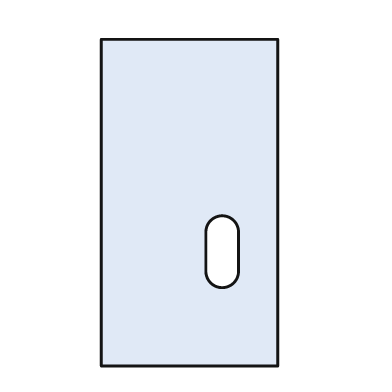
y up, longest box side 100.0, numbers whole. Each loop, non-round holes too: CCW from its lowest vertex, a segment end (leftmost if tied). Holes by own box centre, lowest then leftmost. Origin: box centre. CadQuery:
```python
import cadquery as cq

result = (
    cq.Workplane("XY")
    .moveTo(-27.0, -50.0)
    .lineTo(27.0, -50.0)
    .lineTo(27.0, 50.0)
    .lineTo(-27.0, 50.0)
    .close()
    .moveTo(5.0, -21.0)
    .threePointArc((10.0, -26.0), (15.0, -21.0))
    .lineTo(15.0, -9.0)
    .threePointArc((10.0, -4.0), (5.0, -9.0))
    .close()
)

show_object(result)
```